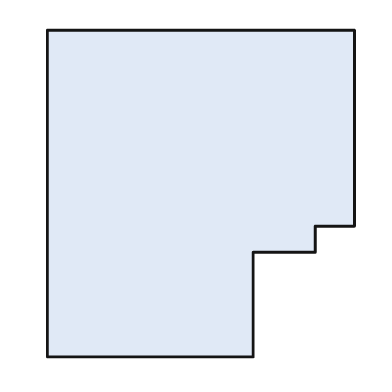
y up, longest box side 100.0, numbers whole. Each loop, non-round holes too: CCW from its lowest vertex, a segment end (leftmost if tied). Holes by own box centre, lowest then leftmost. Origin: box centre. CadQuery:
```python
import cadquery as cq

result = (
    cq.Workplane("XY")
    .moveTo(-47.0, -50.0)
    .lineTo(16.0, -50.0)
    .lineTo(16.0, -18.0)
    .lineTo(35.0, -18.0)
    .lineTo(35.0, -10.0)
    .lineTo(47.0, -10.0)
    .lineTo(47.0, 50.0)
    .lineTo(-47.0, 50.0)
    .close()
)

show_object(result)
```